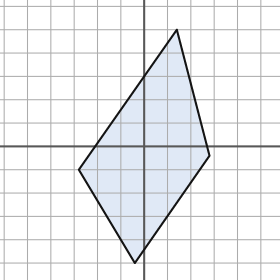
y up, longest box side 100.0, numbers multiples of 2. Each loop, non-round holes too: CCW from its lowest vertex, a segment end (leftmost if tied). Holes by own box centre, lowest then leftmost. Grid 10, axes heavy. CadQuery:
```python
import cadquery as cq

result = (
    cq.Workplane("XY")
    .moveTo(-4.0, -50.0)
    .lineTo(28.0, -4.0)
    .lineTo(14.0, 50.0)
    .lineTo(-28.0, -10.0)
    .close()
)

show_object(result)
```